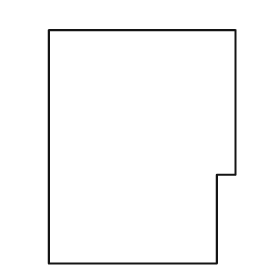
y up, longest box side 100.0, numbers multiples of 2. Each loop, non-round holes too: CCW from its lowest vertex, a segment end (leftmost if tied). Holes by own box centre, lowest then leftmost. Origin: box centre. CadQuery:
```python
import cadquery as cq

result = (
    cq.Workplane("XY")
    .moveTo(-40.0, -50.0)
    .lineTo(32.0, -50.0)
    .lineTo(32.0, -12.0)
    .lineTo(40.0, -12.0)
    .lineTo(40.0, 50.0)
    .lineTo(-40.0, 50.0)
    .close()
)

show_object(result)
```